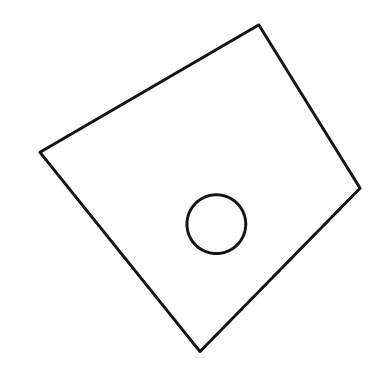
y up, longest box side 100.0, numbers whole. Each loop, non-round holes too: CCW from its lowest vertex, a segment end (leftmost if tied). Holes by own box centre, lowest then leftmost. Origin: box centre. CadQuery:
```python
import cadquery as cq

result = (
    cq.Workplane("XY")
    .moveTo(0.0, -50.0)
    .lineTo(49.0, 0.0)
    .lineTo(18.0, 50.0)
    .lineTo(-49.0, 11.0)
    .close()
    .moveTo(5.0, -11.0)
    .circle(9.0)
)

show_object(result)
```